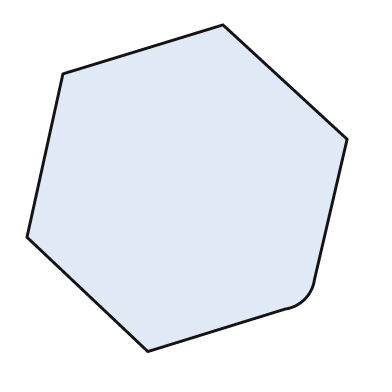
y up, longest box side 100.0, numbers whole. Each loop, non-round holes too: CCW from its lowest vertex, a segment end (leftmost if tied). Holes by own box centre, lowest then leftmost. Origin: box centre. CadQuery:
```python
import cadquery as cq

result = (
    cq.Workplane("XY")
    .moveTo(-12.0, -50.0)
    .lineTo(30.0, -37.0)
    .threePointArc((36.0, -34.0), (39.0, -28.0))
    .lineTo(49.0, 15.0)
    .lineTo(11.0, 50.0)
    .lineTo(-38.0, 35.0)
    .lineTo(-49.0, -15.0)
    .close()
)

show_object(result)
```